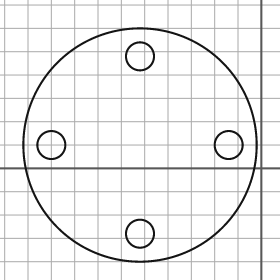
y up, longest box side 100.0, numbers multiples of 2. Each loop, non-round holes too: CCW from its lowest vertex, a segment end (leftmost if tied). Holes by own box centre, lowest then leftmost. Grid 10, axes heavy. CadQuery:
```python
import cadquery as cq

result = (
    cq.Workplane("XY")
    .moveTo(-52.0, 10.0)
    .circle(50.0)
    .moveTo(-52.0, -28.0)
    .circle(6.0)
    .moveTo(-90.0, 10.0)
    .circle(6.0)
    .moveTo(-14.0, 10.0)
    .circle(6.0)
    .moveTo(-52.0, 48.0)
    .circle(6.0)
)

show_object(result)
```